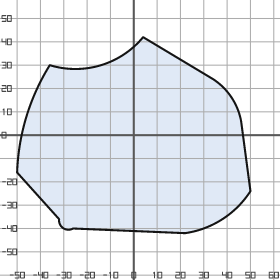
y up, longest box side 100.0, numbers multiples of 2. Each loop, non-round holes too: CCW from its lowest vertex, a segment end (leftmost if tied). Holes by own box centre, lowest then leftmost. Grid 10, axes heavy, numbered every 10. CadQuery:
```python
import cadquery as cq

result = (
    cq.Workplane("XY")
    .moveTo(22.0, -42.0)
    .threePointArc((38.0, -36.0), (50.0, -24.0))
    .lineTo(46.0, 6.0)
    .threePointArc((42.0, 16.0), (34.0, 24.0))
    .lineTo(4.0, 42.0)
    .threePointArc((-14.0, 30.0), (-36.0, 30.0))
    .threePointArc((-46.0, 8.0), (-50.0, -16.0))
    .lineTo(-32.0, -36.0)
    .threePointArc((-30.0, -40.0), (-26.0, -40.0))
    .close()
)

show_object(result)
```